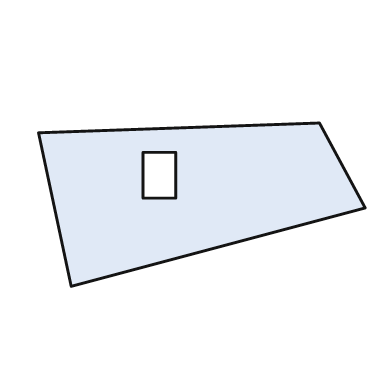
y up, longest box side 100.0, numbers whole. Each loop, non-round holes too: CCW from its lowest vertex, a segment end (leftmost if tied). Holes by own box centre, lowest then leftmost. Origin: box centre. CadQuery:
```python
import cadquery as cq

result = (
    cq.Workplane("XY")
    .moveTo(-40.0, -25.0)
    .lineTo(50.0, -1.0)
    .lineTo(36.0, 25.0)
    .lineTo(-50.0, 22.0)
    .close()
    .moveTo(-18.0, 2.0)
    .lineTo(-8.0, 2.0)
    .lineTo(-8.0, 16.0)
    .lineTo(-18.0, 16.0)
    .close()
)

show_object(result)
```